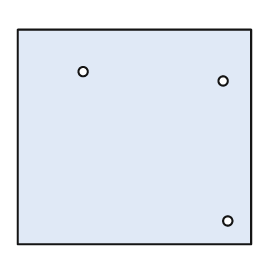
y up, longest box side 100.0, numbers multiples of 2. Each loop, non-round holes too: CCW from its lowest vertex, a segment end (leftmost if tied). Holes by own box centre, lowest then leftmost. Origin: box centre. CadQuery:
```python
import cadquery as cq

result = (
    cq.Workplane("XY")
    .moveTo(-50.0, -46.0)
    .lineTo(50.0, -46.0)
    .lineTo(50.0, 46.0)
    .lineTo(-50.0, 46.0)
    .close()
    .moveTo(40.0, -36.0)
    .circle(2.0)
    .moveTo(38.0, 24.0)
    .circle(2.0)
    .moveTo(-22.0, 28.0)
    .circle(2.0)
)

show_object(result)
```